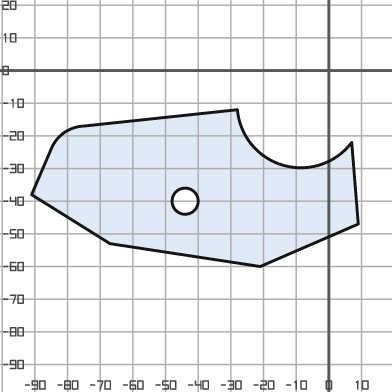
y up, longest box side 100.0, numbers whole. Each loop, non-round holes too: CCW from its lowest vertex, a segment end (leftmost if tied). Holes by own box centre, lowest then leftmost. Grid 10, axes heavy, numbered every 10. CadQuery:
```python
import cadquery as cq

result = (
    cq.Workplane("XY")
    .moveTo(-21.0, -60.0)
    .lineTo(9.0, -47.0)
    .lineTo(7.0, -22.0)
    .threePointArc((-14.0, -29.0), (-28.0, -12.0))
    .lineTo(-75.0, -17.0)
    .threePointArc((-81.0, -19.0), (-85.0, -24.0))
    .lineTo(-91.0, -38.0)
    .lineTo(-67.0, -53.0)
    .close()
    .moveTo(-44.0, -40.0)
    .circle(4.0)
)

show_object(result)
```